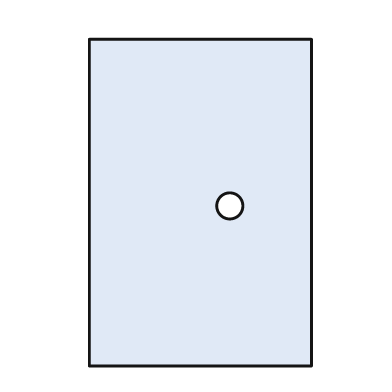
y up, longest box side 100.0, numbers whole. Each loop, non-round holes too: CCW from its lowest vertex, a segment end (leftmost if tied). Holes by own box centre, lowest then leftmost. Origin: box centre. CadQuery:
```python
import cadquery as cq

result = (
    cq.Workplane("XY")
    .moveTo(-34.0, -50.0)
    .lineTo(34.0, -50.0)
    .lineTo(34.0, 50.0)
    .lineTo(-34.0, 50.0)
    .close()
    .moveTo(9.0, -1.0)
    .circle(4.0)
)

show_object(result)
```